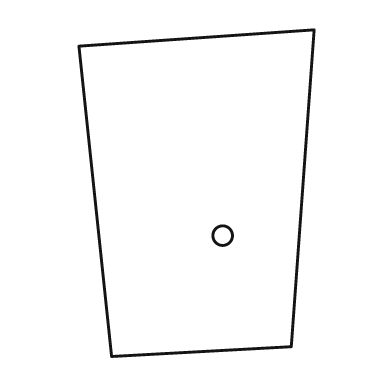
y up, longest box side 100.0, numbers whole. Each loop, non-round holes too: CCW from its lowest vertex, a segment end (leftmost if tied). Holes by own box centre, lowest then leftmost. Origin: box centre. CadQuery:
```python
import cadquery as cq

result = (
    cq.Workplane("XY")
    .moveTo(-26.0, -50.0)
    .lineTo(29.0, -47.0)
    .lineTo(36.0, 50.0)
    .lineTo(-36.0, 45.0)
    .close()
    .moveTo(8.0, -13.0)
    .circle(3.0)
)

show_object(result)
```